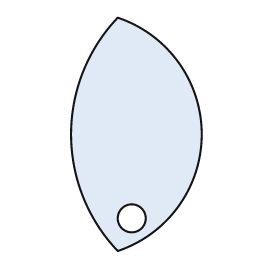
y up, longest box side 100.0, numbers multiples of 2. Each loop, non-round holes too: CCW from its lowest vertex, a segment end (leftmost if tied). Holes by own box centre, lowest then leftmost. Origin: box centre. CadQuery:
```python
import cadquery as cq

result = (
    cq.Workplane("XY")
    .moveTo(-8.0, -50.0)
    .threePointArc((28.0, 0.0), (-8.0, 50.0))
    .threePointArc((-28.0, 0.0), (-8.0, -50.0))
    .close()
    .moveTo(-2.0, -36.0)
    .circle(6.0)
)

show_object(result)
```